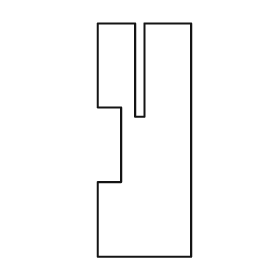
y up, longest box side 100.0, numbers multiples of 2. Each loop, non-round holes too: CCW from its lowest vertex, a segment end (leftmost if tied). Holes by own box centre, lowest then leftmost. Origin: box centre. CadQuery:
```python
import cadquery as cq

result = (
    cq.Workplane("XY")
    .moveTo(-20.0, -50.0)
    .lineTo(20.0, -50.0)
    .lineTo(20.0, 50.0)
    .lineTo(0.0, 50.0)
    .lineTo(0.0, 10.0)
    .lineTo(-4.0, 10.0)
    .lineTo(-4.0, 50.0)
    .lineTo(-20.0, 50.0)
    .lineTo(-20.0, 14.0)
    .lineTo(-10.0, 14.0)
    .lineTo(-10.0, -18.0)
    .lineTo(-20.0, -18.0)
    .close()
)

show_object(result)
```